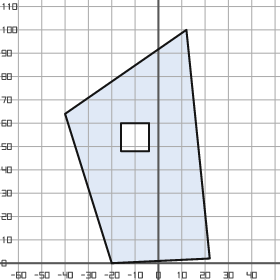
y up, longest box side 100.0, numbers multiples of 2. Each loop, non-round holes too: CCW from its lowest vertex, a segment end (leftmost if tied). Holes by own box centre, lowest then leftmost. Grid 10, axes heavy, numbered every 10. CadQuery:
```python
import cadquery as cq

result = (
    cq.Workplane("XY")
    .moveTo(-20.0, 0.0)
    .lineTo(22.0, 2.0)
    .lineTo(12.0, 100.0)
    .lineTo(-40.0, 64.0)
    .close()
    .moveTo(-16.0, 48.0)
    .lineTo(-4.0, 48.0)
    .lineTo(-4.0, 60.0)
    .lineTo(-16.0, 60.0)
    .close()
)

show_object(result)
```